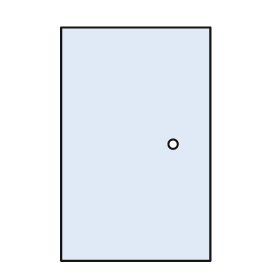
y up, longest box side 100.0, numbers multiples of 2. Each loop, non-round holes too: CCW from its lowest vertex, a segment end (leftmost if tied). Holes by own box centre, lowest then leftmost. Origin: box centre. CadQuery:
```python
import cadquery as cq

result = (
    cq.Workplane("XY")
    .moveTo(-32.0, -50.0)
    .lineTo(32.0, -50.0)
    .lineTo(32.0, 50.0)
    .lineTo(-32.0, 50.0)
    .close()
    .moveTo(16.0, 0.0)
    .circle(2.0)
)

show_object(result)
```